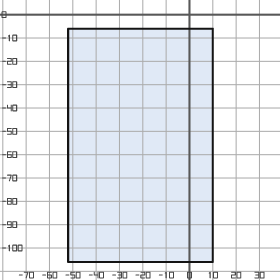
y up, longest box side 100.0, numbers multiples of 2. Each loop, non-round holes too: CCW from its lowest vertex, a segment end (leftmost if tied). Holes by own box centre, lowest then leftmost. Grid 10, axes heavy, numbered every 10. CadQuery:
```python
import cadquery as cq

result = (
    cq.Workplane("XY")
    .moveTo(-52.0, -106.0)
    .lineTo(10.0, -106.0)
    .lineTo(10.0, -6.0)
    .lineTo(-52.0, -6.0)
    .close()
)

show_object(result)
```